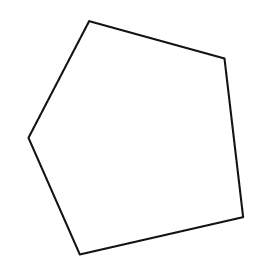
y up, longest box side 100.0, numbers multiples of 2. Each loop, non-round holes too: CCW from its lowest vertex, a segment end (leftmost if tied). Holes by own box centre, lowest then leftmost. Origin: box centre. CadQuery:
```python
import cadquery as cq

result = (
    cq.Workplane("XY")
    .moveTo(-24.0, -50.0)
    .lineTo(46.0, -34.0)
    .lineTo(38.0, 34.0)
    .lineTo(-20.0, 50.0)
    .lineTo(-46.0, 0.0)
    .close()
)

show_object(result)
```